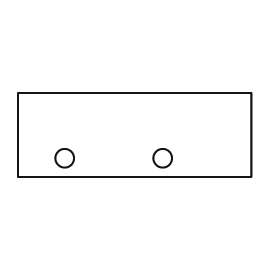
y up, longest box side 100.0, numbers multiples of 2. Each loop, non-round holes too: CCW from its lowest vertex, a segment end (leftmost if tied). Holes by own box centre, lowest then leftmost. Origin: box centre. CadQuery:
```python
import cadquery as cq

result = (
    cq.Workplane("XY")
    .moveTo(-50.0, -18.0)
    .lineTo(50.0, -18.0)
    .lineTo(50.0, 18.0)
    .lineTo(-50.0, 18.0)
    .close()
    .moveTo(-30.0, -10.0)
    .circle(4.0)
    .moveTo(12.0, -10.0)
    .circle(4.0)
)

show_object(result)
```